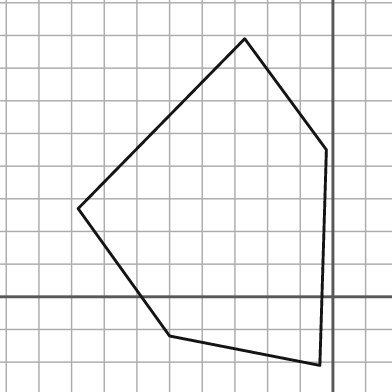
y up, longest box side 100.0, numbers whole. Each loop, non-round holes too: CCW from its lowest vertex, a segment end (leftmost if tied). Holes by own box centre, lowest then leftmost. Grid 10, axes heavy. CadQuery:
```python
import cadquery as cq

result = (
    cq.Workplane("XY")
    .moveTo(-4.0, -21.0)
    .lineTo(-2.0, 45.0)
    .lineTo(-27.0, 79.0)
    .lineTo(-78.0, 27.0)
    .lineTo(-50.0, -12.0)
    .close()
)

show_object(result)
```